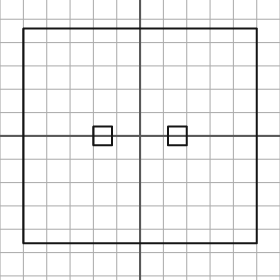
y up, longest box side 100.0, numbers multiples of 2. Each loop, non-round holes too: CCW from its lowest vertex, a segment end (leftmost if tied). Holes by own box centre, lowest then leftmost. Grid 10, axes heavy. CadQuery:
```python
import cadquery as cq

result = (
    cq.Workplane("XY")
    .moveTo(-50.0, -46.0)
    .lineTo(50.0, -46.0)
    .lineTo(50.0, 46.0)
    .lineTo(-50.0, 46.0)
    .close()
    .moveTo(-20.0, -4.0)
    .lineTo(-12.0, -4.0)
    .lineTo(-12.0, 4.0)
    .lineTo(-20.0, 4.0)
    .close()
    .moveTo(12.0, -4.0)
    .lineTo(20.0, -4.0)
    .lineTo(20.0, 4.0)
    .lineTo(12.0, 4.0)
    .close()
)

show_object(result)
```